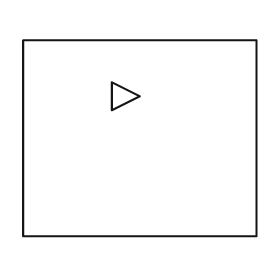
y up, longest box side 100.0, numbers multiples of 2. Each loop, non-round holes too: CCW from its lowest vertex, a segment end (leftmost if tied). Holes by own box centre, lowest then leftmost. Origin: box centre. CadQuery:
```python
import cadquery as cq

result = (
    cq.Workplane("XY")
    .moveTo(-50.0, -42.0)
    .lineTo(50.0, -42.0)
    .lineTo(50.0, 42.0)
    .lineTo(-50.0, 42.0)
    .close()
    .moveTo(-12.0, 12.0)
    .lineTo(0.0, 18.0)
    .lineTo(-12.0, 24.0)
    .close()
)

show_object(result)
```